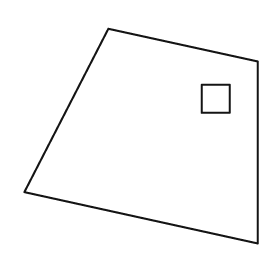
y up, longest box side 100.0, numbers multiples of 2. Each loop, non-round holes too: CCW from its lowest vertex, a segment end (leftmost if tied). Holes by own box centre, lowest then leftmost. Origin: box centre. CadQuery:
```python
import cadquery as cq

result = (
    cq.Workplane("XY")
    .moveTo(50.0, -46.0)
    .lineTo(50.0, 32.0)
    .lineTo(-14.0, 46.0)
    .lineTo(-50.0, -24.0)
    .close()
    .moveTo(26.0, 10.0)
    .lineTo(38.0, 10.0)
    .lineTo(38.0, 22.0)
    .lineTo(26.0, 22.0)
    .close()
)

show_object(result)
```